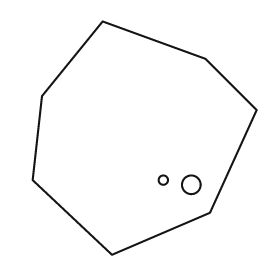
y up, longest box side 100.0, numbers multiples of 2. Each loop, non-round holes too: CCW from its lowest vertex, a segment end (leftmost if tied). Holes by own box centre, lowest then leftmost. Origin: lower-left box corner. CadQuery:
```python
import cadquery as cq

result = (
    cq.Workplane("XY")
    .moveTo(34.0, 0.0)
    .lineTo(76.0, 18.0)
    .lineTo(96.0, 62.0)
    .lineTo(74.0, 84.0)
    .lineTo(30.0, 100.0)
    .lineTo(4.0, 68.0)
    .lineTo(0.0, 32.0)
    .close()
    .moveTo(68.0, 30.0)
    .circle(4.0)
    .moveTo(56.0, 32.0)
    .circle(2.0)
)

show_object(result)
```